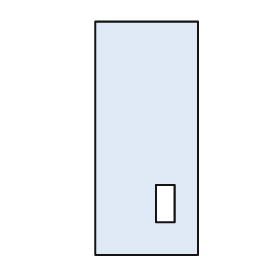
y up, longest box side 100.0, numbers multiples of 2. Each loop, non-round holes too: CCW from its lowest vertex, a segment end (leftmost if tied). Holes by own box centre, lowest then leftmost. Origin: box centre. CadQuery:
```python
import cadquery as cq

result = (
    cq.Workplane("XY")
    .moveTo(-22.0, -50.0)
    .lineTo(22.0, -50.0)
    .lineTo(22.0, 50.0)
    .lineTo(-22.0, 50.0)
    .close()
    .moveTo(4.0, -36.0)
    .lineTo(12.0, -36.0)
    .lineTo(12.0, -20.0)
    .lineTo(4.0, -20.0)
    .close()
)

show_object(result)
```